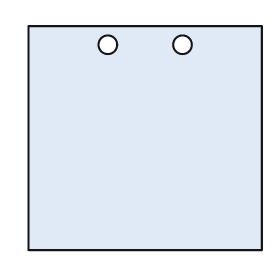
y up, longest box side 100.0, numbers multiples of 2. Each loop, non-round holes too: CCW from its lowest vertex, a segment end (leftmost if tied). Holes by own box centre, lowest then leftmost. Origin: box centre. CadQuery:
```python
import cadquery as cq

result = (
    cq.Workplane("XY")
    .moveTo(-50.0, -48.0)
    .lineTo(50.0, -48.0)
    .lineTo(50.0, 48.0)
    .lineTo(-50.0, 48.0)
    .close()
    .moveTo(-16.0, 40.0)
    .circle(4.0)
    .moveTo(16.0, 40.0)
    .circle(4.0)
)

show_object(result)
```